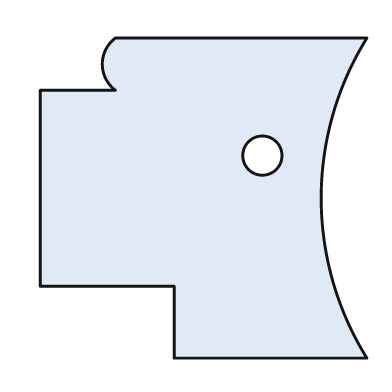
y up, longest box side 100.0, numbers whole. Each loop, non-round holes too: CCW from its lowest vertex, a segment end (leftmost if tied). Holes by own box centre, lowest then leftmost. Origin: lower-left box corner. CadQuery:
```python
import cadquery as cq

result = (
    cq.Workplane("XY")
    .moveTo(41.0, 0.0)
    .lineTo(100.0, 0.0)
    .threePointArc((86.0, 49.0), (100.0, 98.0))
    .lineTo(23.0, 98.0)
    .threePointArc((19.0, 90.0), (23.0, 82.0))
    .lineTo(0.0, 82.0)
    .lineTo(0.0, 22.0)
    .lineTo(41.0, 22.0)
    .close()
    .moveTo(68.0, 62.0)
    .circle(6.0)
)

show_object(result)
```